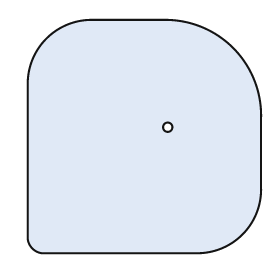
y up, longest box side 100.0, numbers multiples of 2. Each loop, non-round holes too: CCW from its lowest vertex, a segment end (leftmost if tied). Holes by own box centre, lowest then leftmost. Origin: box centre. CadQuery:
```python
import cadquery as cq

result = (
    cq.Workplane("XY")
    .moveTo(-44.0, -50.0)
    .lineTo(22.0, -50.0)
    .threePointArc((42.0, -42.0), (50.0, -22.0))
    .lineTo(50.0, 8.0)
    .threePointArc((38.0, 38.0), (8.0, 50.0))
    .lineTo(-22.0, 50.0)
    .threePointArc((-42.0, 42.0), (-50.0, 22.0))
    .lineTo(-50.0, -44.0)
    .threePointArc((-48.0, -48.0), (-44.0, -50.0))
    .close()
    .moveTo(10.0, 4.0)
    .circle(2.0)
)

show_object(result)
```